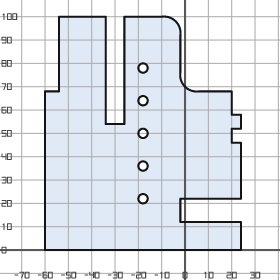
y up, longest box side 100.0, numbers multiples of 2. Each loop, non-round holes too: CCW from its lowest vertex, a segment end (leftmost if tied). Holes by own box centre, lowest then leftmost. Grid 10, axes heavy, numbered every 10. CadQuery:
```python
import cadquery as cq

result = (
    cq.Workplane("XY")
    .moveTo(-60.0, 0.0)
    .lineTo(24.0, 0.0)
    .lineTo(24.0, 12.0)
    .lineTo(-2.0, 12.0)
    .lineTo(-2.0, 22.0)
    .lineTo(24.0, 22.0)
    .lineTo(24.0, 46.0)
    .lineTo(20.0, 46.0)
    .lineTo(20.0, 52.0)
    .lineTo(24.0, 52.0)
    .lineTo(24.0, 58.0)
    .lineTo(20.0, 58.0)
    .lineTo(20.0, 68.0)
    .lineTo(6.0, 68.0)
    .threePointArc((0.0, 70.0), (-2.0, 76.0))
    .lineTo(-2.0, 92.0)
    .threePointArc((-4.0, 98.0), (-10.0, 100.0))
    .lineTo(-26.0, 100.0)
    .lineTo(-26.0, 54.0)
    .lineTo(-34.0, 54.0)
    .lineTo(-34.0, 100.0)
    .lineTo(-54.0, 100.0)
    .lineTo(-54.0, 68.0)
    .lineTo(-60.0, 68.0)
    .close()
    .moveTo(-18.0, 22.0)
    .circle(2.0)
    .moveTo(-18.0, 36.0)
    .circle(2.0)
    .moveTo(-18.0, 50.0)
    .circle(2.0)
    .moveTo(-18.0, 64.0)
    .circle(2.0)
    .moveTo(-18.0, 78.0)
    .circle(2.0)
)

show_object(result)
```